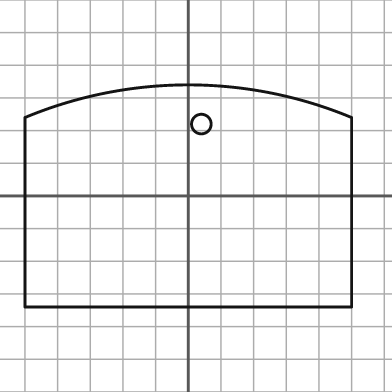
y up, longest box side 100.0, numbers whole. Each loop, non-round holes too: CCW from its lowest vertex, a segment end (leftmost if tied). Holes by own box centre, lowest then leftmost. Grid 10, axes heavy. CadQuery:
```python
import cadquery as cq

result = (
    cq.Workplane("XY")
    .moveTo(-50.0, -34.0)
    .lineTo(50.0, -34.0)
    .lineTo(50.0, 24.0)
    .threePointArc((0.0, 34.0), (-50.0, 24.0))
    .close()
    .moveTo(4.0, 22.0)
    .circle(3.0)
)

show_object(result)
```